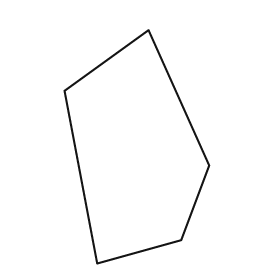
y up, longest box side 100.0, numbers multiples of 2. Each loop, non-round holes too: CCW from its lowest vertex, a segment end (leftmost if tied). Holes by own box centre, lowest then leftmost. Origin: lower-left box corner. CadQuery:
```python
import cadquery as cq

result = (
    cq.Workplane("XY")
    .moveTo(14.0, 0.0)
    .lineTo(50.0, 10.0)
    .lineTo(62.0, 42.0)
    .lineTo(36.0, 100.0)
    .lineTo(0.0, 74.0)
    .close()
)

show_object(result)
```